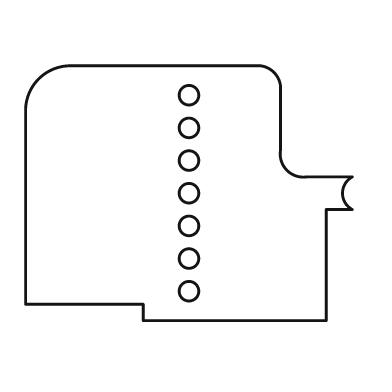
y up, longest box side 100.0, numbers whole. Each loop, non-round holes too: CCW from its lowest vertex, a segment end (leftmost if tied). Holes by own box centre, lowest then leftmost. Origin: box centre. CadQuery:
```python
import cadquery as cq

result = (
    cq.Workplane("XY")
    .moveTo(-14.0, -39.0)
    .lineTo(42.0, -39.0)
    .lineTo(42.0, -5.0)
    .lineTo(50.0, -5.0)
    .threePointArc((47.0, 0.0), (50.0, 5.0))
    .lineTo(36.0, 5.0)
    .threePointArc((30.0, 7.0), (28.0, 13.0))
    .lineTo(28.0, 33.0)
    .threePointArc((26.0, 37.0), (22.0, 39.0))
    .lineTo(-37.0, 39.0)
    .threePointArc((-46.0, 35.0), (-50.0, 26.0))
    .lineTo(-50.0, -34.0)
    .lineTo(-14.0, -34.0)
    .close()
    .moveTo(0.0, -30.0)
    .circle(3.0)
    .moveTo(0.0, -20.0)
    .circle(3.0)
    .moveTo(0.0, -10.0)
    .circle(3.0)
    .moveTo(0.0, 0.0)
    .circle(3.0)
    .moveTo(0.0, 10.0)
    .circle(3.0)
    .moveTo(0.0, 20.0)
    .circle(3.0)
    .moveTo(0.0, 30.0)
    .circle(3.0)
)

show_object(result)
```